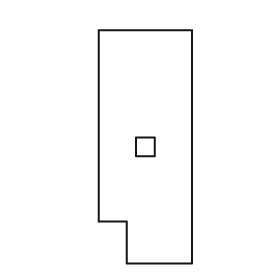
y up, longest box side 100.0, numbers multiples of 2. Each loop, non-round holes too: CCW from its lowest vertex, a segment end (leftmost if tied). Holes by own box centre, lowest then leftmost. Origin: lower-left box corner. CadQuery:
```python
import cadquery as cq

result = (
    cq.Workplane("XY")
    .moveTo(12.0, 0.0)
    .lineTo(40.0, 0.0)
    .lineTo(40.0, 100.0)
    .lineTo(0.0, 100.0)
    .lineTo(0.0, 18.0)
    .lineTo(12.0, 18.0)
    .close()
    .moveTo(16.0, 46.0)
    .lineTo(24.0, 46.0)
    .lineTo(24.0, 54.0)
    .lineTo(16.0, 54.0)
    .close()
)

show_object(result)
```